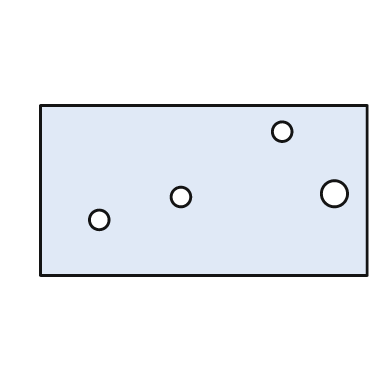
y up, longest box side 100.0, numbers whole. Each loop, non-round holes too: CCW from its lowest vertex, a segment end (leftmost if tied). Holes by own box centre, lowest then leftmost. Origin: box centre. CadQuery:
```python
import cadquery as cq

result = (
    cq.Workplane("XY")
    .moveTo(-50.0, -26.0)
    .lineTo(50.0, -26.0)
    .lineTo(50.0, 26.0)
    .lineTo(-50.0, 26.0)
    .close()
    .moveTo(-32.0, -9.0)
    .circle(3.0)
    .moveTo(-7.0, -2.0)
    .circle(3.0)
    .moveTo(40.0, -1.0)
    .circle(4.0)
    .moveTo(24.0, 18.0)
    .circle(3.0)
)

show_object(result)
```